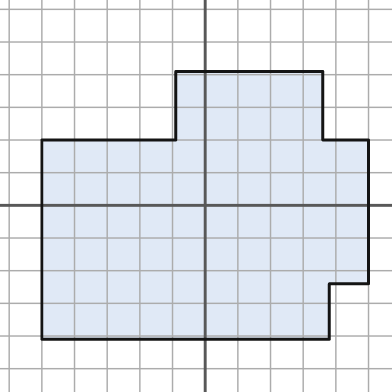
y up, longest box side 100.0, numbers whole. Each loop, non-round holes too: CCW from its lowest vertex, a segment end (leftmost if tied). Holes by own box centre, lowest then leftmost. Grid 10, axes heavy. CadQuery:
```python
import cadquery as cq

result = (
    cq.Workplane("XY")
    .moveTo(-50.0, -41.0)
    .lineTo(38.0, -41.0)
    .lineTo(38.0, -24.0)
    .lineTo(50.0, -24.0)
    .lineTo(50.0, 20.0)
    .lineTo(36.0, 20.0)
    .lineTo(36.0, 41.0)
    .lineTo(-9.0, 41.0)
    .lineTo(-9.0, 20.0)
    .lineTo(-50.0, 20.0)
    .close()
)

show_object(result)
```